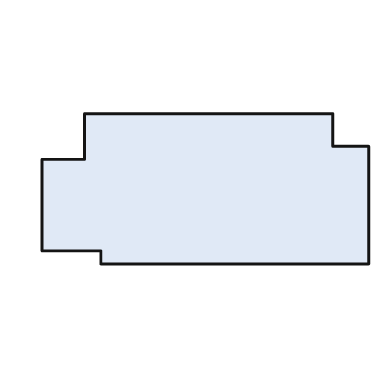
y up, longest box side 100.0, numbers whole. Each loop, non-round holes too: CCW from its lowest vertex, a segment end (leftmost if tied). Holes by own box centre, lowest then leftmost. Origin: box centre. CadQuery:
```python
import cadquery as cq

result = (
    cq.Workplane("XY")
    .moveTo(-32.0, -23.0)
    .lineTo(50.0, -23.0)
    .lineTo(50.0, 13.0)
    .lineTo(39.0, 13.0)
    .lineTo(39.0, 23.0)
    .lineTo(-37.0, 23.0)
    .lineTo(-37.0, 9.0)
    .lineTo(-50.0, 9.0)
    .lineTo(-50.0, -19.0)
    .lineTo(-32.0, -19.0)
    .close()
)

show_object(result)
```